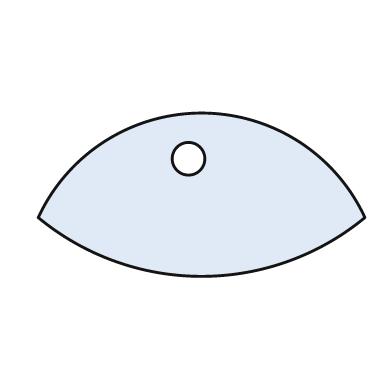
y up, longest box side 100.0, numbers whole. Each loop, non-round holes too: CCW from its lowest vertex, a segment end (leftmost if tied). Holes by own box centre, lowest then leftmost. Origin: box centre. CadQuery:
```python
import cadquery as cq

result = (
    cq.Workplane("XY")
    .moveTo(-50.0, -7.0)
    .threePointArc((0.0, -25.0), (50.0, -7.0))
    .threePointArc((0.0, 25.0), (-50.0, -7.0))
    .close()
    .moveTo(-4.0, 11.0)
    .circle(5.0)
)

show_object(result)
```